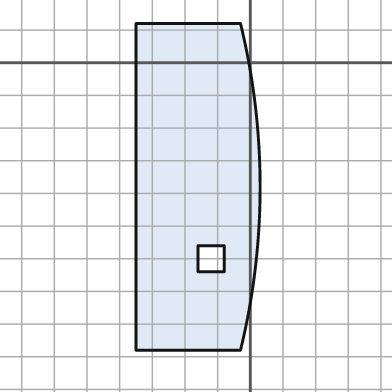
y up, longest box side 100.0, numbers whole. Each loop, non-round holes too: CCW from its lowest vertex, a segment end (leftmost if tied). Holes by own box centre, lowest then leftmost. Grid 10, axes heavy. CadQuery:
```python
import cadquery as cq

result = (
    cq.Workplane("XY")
    .moveTo(-35.0, -88.0)
    .lineTo(-3.0, -88.0)
    .threePointArc((3.0, -38.0), (-3.0, 12.0))
    .lineTo(-35.0, 12.0)
    .close()
    .moveTo(-16.0, -64.0)
    .lineTo(-8.0, -64.0)
    .lineTo(-8.0, -56.0)
    .lineTo(-16.0, -56.0)
    .close()
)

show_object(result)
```